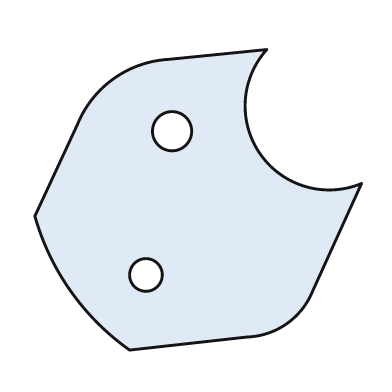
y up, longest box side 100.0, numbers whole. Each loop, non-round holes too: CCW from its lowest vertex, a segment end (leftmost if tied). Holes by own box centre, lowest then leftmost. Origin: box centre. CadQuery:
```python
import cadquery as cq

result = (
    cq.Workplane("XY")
    .moveTo(-21.0, -46.0)
    .lineTo(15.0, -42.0)
    .threePointArc((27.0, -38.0), (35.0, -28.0))
    .lineTo(50.0, 5.0)
    .threePointArc((19.0, 14.0), (21.0, 46.0))
    .lineTo(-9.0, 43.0)
    .threePointArc((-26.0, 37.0), (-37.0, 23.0))
    .lineTo(-50.0, -5.0)
    .threePointArc((-39.0, -28.0), (-21.0, -46.0))
    .close()
    .moveTo(-16.0, -23.0)
    .circle(5.0)
    .moveTo(-8.0, 21.0)
    .circle(6.0)
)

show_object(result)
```